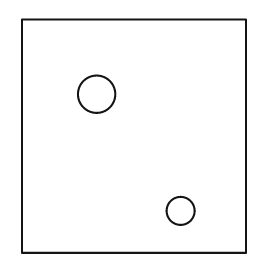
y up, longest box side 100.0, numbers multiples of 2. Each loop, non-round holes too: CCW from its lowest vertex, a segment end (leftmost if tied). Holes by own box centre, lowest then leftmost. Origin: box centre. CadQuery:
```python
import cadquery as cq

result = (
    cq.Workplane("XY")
    .moveTo(-48.0, -50.0)
    .lineTo(48.0, -50.0)
    .lineTo(48.0, 50.0)
    .lineTo(-48.0, 50.0)
    .close()
    .moveTo(20.0, -32.0)
    .circle(6.0)
    .moveTo(-16.0, 18.0)
    .circle(8.0)
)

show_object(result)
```